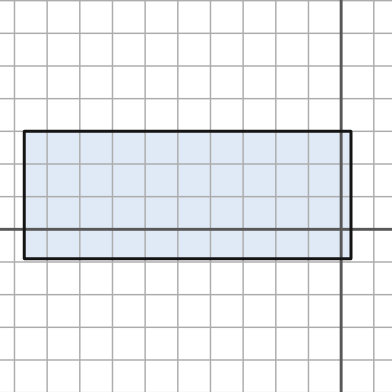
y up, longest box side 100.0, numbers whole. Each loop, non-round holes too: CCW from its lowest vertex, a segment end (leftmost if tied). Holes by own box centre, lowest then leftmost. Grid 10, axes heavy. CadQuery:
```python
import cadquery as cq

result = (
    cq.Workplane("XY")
    .moveTo(-97.0, -9.0)
    .lineTo(3.0, -9.0)
    .lineTo(3.0, 30.0)
    .lineTo(-97.0, 30.0)
    .close()
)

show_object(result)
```